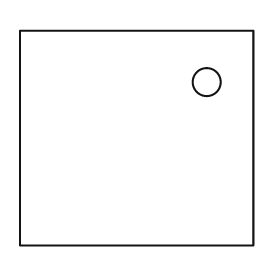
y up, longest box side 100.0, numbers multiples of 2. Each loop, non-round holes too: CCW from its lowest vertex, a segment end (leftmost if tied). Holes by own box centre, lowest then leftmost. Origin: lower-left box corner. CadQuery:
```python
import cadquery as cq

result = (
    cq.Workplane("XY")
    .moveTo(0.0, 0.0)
    .lineTo(100.0, 0.0)
    .lineTo(100.0, 92.0)
    .lineTo(0.0, 92.0)
    .close()
    .moveTo(80.0, 70.0)
    .circle(6.0)
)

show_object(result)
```